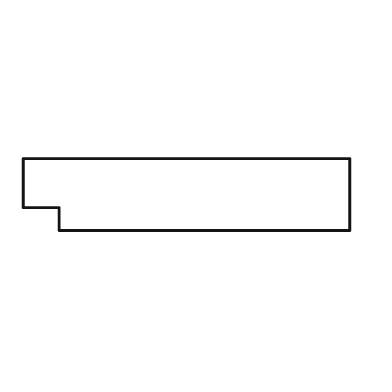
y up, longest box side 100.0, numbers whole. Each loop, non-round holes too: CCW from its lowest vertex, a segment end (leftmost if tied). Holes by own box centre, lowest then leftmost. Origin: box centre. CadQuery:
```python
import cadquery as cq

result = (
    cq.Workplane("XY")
    .moveTo(-39.0, -11.0)
    .lineTo(50.0, -11.0)
    .lineTo(50.0, 11.0)
    .lineTo(-50.0, 11.0)
    .lineTo(-50.0, -4.0)
    .lineTo(-39.0, -4.0)
    .close()
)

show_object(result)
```